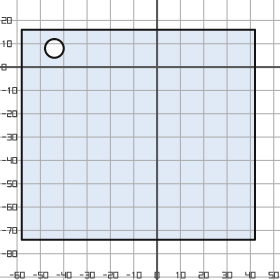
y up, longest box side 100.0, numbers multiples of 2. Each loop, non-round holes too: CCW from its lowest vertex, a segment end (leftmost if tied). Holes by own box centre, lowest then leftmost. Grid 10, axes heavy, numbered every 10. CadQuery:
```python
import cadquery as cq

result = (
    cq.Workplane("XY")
    .moveTo(-58.0, -74.0)
    .lineTo(42.0, -74.0)
    .lineTo(42.0, 16.0)
    .lineTo(-58.0, 16.0)
    .close()
    .moveTo(-44.0, 8.0)
    .circle(4.0)
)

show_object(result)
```